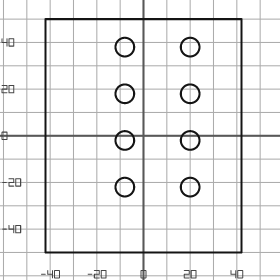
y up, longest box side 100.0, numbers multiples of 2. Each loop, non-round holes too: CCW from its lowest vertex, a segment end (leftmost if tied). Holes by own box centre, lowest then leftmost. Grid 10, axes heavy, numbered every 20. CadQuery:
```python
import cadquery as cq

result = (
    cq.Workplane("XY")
    .moveTo(-42.0, -50.0)
    .lineTo(42.0, -50.0)
    .lineTo(42.0, 50.0)
    .lineTo(-42.0, 50.0)
    .close()
    .moveTo(-8.0, -22.0)
    .circle(4.0)
    .moveTo(20.0, -22.0)
    .circle(4.0)
    .moveTo(-8.0, -2.0)
    .circle(4.0)
    .moveTo(20.0, -2.0)
    .circle(4.0)
    .moveTo(-8.0, 18.0)
    .circle(4.0)
    .moveTo(20.0, 18.0)
    .circle(4.0)
    .moveTo(-8.0, 38.0)
    .circle(4.0)
    .moveTo(20.0, 38.0)
    .circle(4.0)
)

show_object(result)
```